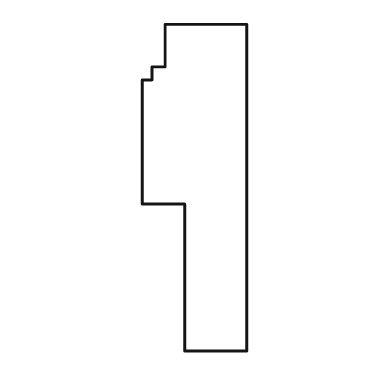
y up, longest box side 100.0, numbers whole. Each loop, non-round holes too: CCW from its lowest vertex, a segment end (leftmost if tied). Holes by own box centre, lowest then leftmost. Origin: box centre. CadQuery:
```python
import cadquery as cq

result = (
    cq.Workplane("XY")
    .moveTo(-3.0, -50.0)
    .lineTo(16.0, -50.0)
    .lineTo(16.0, 50.0)
    .lineTo(-9.0, 50.0)
    .lineTo(-9.0, 37.0)
    .lineTo(-13.0, 37.0)
    .lineTo(-13.0, 33.0)
    .lineTo(-16.0, 33.0)
    .lineTo(-16.0, -5.0)
    .lineTo(-3.0, -5.0)
    .close()
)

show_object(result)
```